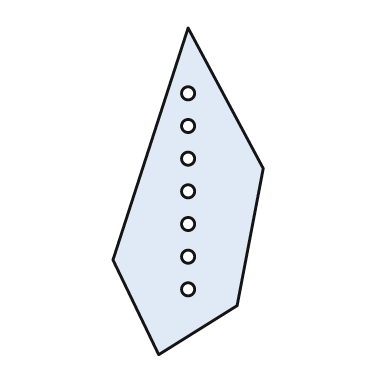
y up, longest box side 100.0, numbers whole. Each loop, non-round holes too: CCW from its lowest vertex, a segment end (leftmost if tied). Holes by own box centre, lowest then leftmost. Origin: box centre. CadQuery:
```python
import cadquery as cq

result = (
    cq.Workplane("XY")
    .moveTo(-9.0, -50.0)
    .lineTo(15.0, -35.0)
    .lineTo(23.0, 7.0)
    .lineTo(0.0, 50.0)
    .lineTo(-23.0, -21.0)
    .close()
    .moveTo(0.0, -30.0)
    .circle(2.0)
    .moveTo(0.0, -20.0)
    .circle(2.0)
    .moveTo(0.0, -10.0)
    .circle(2.0)
    .moveTo(0.0, 0.0)
    .circle(2.0)
    .moveTo(0.0, 10.0)
    .circle(2.0)
    .moveTo(0.0, 20.0)
    .circle(2.0)
    .moveTo(0.0, 30.0)
    .circle(2.0)
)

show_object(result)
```